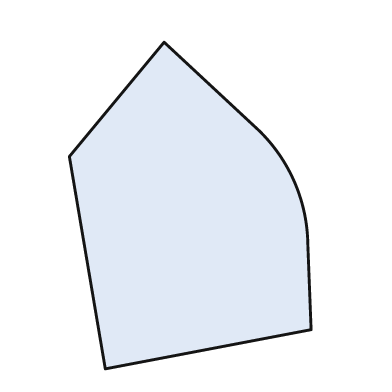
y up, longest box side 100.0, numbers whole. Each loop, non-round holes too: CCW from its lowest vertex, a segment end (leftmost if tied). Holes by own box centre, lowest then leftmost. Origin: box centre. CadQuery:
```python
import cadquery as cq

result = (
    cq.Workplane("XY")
    .moveTo(-26.0, -50.0)
    .lineTo(37.0, -38.0)
    .lineTo(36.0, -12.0)
    .threePointArc((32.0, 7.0), (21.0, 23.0))
    .lineTo(-8.0, 50.0)
    .lineTo(-37.0, 15.0)
    .close()
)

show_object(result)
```